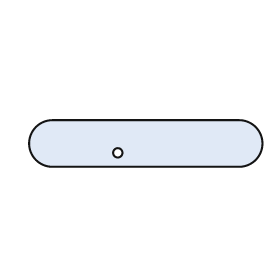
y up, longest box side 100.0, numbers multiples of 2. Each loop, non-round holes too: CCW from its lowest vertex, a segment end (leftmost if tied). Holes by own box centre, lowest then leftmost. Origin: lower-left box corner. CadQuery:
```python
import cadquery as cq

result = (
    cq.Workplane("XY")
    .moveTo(10.0, 0.0)
    .lineTo(90.0, 0.0)
    .threePointArc((100.0, 10.0), (90.0, 20.0))
    .lineTo(10.0, 20.0)
    .threePointArc((0.0, 10.0), (10.0, 0.0))
    .close()
    .moveTo(38.0, 6.0)
    .circle(2.0)
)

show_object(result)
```